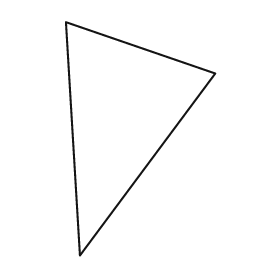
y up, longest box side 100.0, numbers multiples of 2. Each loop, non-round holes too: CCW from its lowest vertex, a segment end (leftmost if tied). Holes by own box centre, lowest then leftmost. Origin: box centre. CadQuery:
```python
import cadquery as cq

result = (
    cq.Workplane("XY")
    .moveTo(-26.0, -50.0)
    .lineTo(32.0, 28.0)
    .lineTo(-32.0, 50.0)
    .close()
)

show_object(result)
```